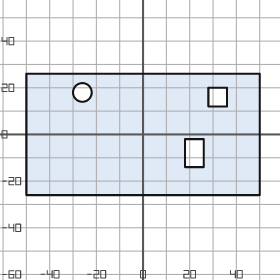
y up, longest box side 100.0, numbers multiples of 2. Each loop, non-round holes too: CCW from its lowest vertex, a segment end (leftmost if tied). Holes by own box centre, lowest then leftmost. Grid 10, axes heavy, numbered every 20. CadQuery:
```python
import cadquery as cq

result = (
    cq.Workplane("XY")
    .moveTo(-50.0, -26.0)
    .lineTo(50.0, -26.0)
    .lineTo(50.0, 26.0)
    .lineTo(-50.0, 26.0)
    .close()
    .moveTo(18.0, -14.0)
    .lineTo(26.0, -14.0)
    .lineTo(26.0, -2.0)
    .lineTo(18.0, -2.0)
    .close()
    .moveTo(28.0, 12.0)
    .lineTo(36.0, 12.0)
    .lineTo(36.0, 20.0)
    .lineTo(28.0, 20.0)
    .close()
    .moveTo(-26.0, 18.0)
    .circle(4.0)
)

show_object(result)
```